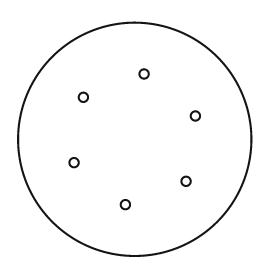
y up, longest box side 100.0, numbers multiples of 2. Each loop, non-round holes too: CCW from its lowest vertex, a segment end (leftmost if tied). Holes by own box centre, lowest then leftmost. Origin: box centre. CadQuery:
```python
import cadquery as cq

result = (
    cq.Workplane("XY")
    .moveTo(0.0, 0.0)
    .circle(50.0)
    .moveTo(-4.0, -28.0)
    .circle(2.0)
    .moveTo(22.0, -18.0)
    .circle(2.0)
    .moveTo(-26.0, -10.0)
    .circle(2.0)
    .moveTo(26.0, 10.0)
    .circle(2.0)
    .moveTo(-22.0, 18.0)
    .circle(2.0)
    .moveTo(4.0, 28.0)
    .circle(2.0)
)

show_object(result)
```